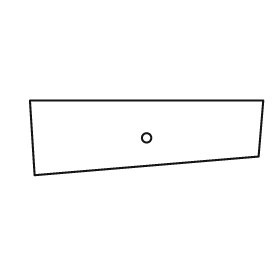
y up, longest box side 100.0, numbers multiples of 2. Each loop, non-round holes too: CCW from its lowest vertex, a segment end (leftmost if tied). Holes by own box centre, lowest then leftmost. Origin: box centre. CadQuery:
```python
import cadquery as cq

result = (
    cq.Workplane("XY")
    .moveTo(-48.0, -16.0)
    .lineTo(48.0, -8.0)
    .lineTo(50.0, 16.0)
    .lineTo(-50.0, 16.0)
    .close()
    .moveTo(0.0, 0.0)
    .circle(2.0)
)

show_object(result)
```